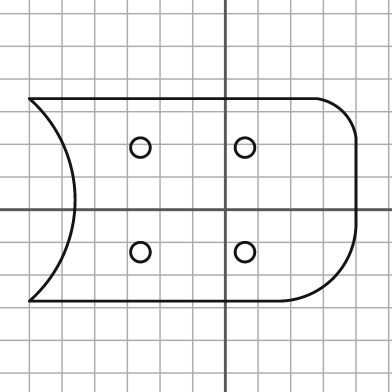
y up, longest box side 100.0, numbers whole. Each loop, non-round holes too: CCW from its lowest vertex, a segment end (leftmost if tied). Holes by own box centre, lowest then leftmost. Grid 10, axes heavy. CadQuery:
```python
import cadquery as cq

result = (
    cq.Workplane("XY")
    .moveTo(-60.0, -28.0)
    .lineTo(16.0, -28.0)
    .threePointArc((33.0, -21.0), (40.0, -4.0))
    .lineTo(40.0, 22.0)
    .threePointArc((36.0, 30.0), (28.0, 34.0))
    .lineTo(-60.0, 34.0)
    .threePointArc((-46.0, 3.0), (-60.0, -28.0))
    .close()
    .moveTo(-26.0, -13.0)
    .circle(3.0)
    .moveTo(6.0, -13.0)
    .circle(3.0)
    .moveTo(-26.0, 19.0)
    .circle(3.0)
    .moveTo(6.0, 19.0)
    .circle(3.0)
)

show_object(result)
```